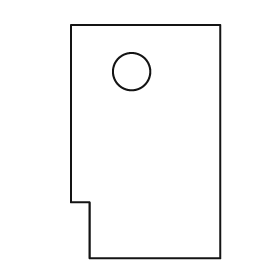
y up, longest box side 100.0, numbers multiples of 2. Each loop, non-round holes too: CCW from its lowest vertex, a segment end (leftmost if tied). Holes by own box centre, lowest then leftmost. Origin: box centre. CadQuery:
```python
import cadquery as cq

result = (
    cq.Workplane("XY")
    .moveTo(-24.0, -50.0)
    .lineTo(32.0, -50.0)
    .lineTo(32.0, 50.0)
    .lineTo(-32.0, 50.0)
    .lineTo(-32.0, -26.0)
    .lineTo(-24.0, -26.0)
    .close()
    .moveTo(-6.0, 30.0)
    .circle(8.0)
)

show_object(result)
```